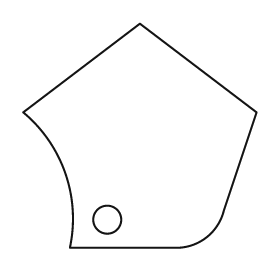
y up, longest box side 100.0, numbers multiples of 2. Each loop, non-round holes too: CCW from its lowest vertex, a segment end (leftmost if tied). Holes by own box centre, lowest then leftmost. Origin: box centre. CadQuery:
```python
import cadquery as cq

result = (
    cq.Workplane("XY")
    .moveTo(-30.0, -48.0)
    .lineTo(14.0, -48.0)
    .threePointArc((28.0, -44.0), (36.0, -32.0))
    .lineTo(50.0, 10.0)
    .lineTo(0.0, 48.0)
    .lineTo(-50.0, 10.0)
    .threePointArc((-32.0, -16.0), (-30.0, -48.0))
    .close()
    .moveTo(-14.0, -36.0)
    .circle(6.0)
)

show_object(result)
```